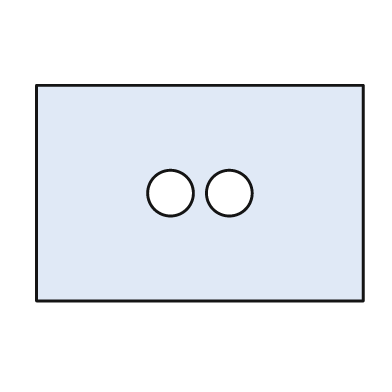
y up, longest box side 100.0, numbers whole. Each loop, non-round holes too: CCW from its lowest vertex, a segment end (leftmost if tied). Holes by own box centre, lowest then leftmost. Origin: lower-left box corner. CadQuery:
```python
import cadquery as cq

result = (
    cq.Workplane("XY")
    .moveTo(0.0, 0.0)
    .lineTo(100.0, 0.0)
    .lineTo(100.0, 66.0)
    .lineTo(0.0, 66.0)
    .close()
    .moveTo(41.0, 33.0)
    .circle(7.0)
    .moveTo(59.0, 33.0)
    .circle(7.0)
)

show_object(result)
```